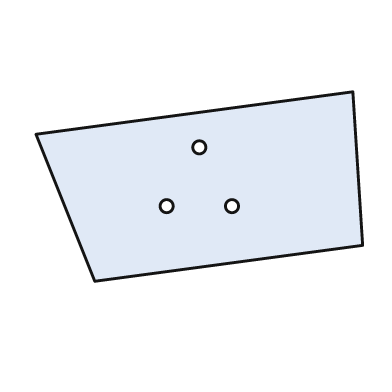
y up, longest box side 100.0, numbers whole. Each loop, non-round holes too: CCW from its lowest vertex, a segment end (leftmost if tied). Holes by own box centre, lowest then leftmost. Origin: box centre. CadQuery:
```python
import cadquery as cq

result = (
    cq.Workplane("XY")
    .moveTo(-32.0, -29.0)
    .lineTo(50.0, -18.0)
    .lineTo(47.0, 29.0)
    .lineTo(-50.0, 16.0)
    .close()
    .moveTo(-10.0, -6.0)
    .circle(2.0)
    .moveTo(10.0, -6.0)
    .circle(2.0)
    .moveTo(0.0, 12.0)
    .circle(2.0)
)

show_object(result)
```